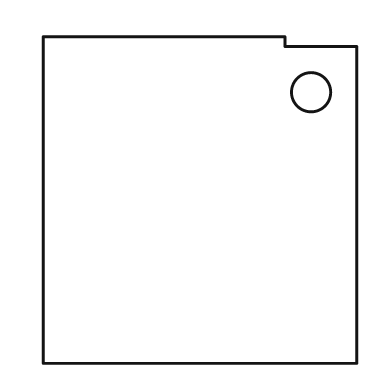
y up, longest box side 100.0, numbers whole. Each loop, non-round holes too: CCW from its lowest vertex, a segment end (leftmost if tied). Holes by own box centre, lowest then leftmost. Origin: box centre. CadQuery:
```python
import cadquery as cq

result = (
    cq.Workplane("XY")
    .moveTo(-48.0, -50.0)
    .lineTo(48.0, -50.0)
    .lineTo(48.0, 47.0)
    .lineTo(26.0, 47.0)
    .lineTo(26.0, 50.0)
    .lineTo(-48.0, 50.0)
    .close()
    .moveTo(34.0, 33.0)
    .circle(6.0)
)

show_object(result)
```